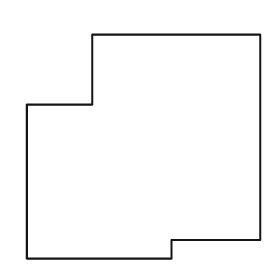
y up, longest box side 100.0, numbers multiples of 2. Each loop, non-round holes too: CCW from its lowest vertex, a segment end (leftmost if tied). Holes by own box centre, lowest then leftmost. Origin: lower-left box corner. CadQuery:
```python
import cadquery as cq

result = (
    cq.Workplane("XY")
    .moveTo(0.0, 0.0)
    .lineTo(62.0, 0.0)
    .lineTo(62.0, 8.0)
    .lineTo(100.0, 8.0)
    .lineTo(100.0, 96.0)
    .lineTo(28.0, 96.0)
    .lineTo(28.0, 66.0)
    .lineTo(0.0, 66.0)
    .close()
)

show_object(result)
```